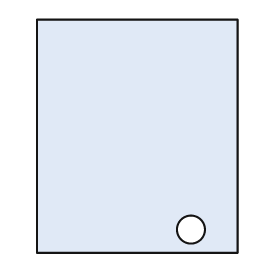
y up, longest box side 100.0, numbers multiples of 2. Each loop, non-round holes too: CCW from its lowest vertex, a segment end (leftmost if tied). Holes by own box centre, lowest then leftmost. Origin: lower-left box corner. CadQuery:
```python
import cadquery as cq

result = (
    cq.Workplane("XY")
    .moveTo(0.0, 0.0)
    .lineTo(86.0, 0.0)
    .lineTo(86.0, 100.0)
    .lineTo(0.0, 100.0)
    .close()
    .moveTo(66.0, 10.0)
    .circle(6.0)
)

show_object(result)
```